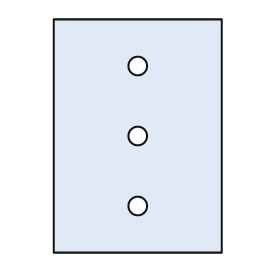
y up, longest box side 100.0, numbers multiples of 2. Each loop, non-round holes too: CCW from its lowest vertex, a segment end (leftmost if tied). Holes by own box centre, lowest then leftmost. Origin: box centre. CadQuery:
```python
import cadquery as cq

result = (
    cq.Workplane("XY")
    .moveTo(-36.0, -50.0)
    .lineTo(36.0, -50.0)
    .lineTo(36.0, 50.0)
    .lineTo(-36.0, 50.0)
    .close()
    .moveTo(0.0, -30.0)
    .circle(4.0)
    .moveTo(0.0, 0.0)
    .circle(4.0)
    .moveTo(0.0, 30.0)
    .circle(4.0)
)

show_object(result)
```